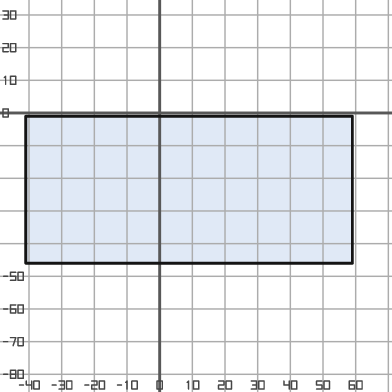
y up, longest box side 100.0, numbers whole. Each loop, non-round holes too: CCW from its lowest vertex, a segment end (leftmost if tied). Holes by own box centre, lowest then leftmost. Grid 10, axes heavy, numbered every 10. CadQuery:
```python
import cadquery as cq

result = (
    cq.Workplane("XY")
    .moveTo(-41.0, -46.0)
    .lineTo(59.0, -46.0)
    .lineTo(59.0, -1.0)
    .lineTo(-41.0, -1.0)
    .close()
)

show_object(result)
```